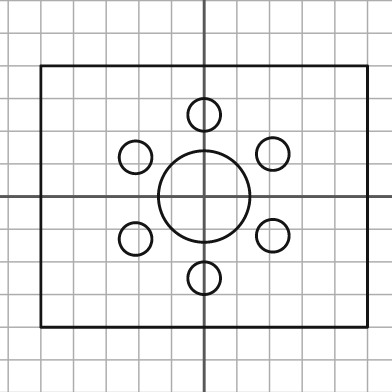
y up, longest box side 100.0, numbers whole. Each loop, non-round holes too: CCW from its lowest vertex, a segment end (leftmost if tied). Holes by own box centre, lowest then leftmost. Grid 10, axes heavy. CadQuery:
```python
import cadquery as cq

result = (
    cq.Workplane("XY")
    .moveTo(-50.0, -40.0)
    .lineTo(50.0, -40.0)
    .lineTo(50.0, 40.0)
    .lineTo(-50.0, 40.0)
    .close()
    .moveTo(0.0, -25.0)
    .circle(5.0)
    .moveTo(-21.0, -13.0)
    .circle(5.0)
    .moveTo(21.0, -12.0)
    .circle(5.0)
    .moveTo(0.0, 0.0)
    .circle(14.0)
    .moveTo(-21.0, 12.0)
    .circle(5.0)
    .moveTo(21.0, 13.0)
    .circle(5.0)
    .moveTo(0.0, 25.0)
    .circle(5.0)
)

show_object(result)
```